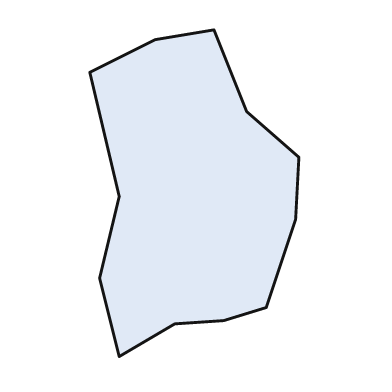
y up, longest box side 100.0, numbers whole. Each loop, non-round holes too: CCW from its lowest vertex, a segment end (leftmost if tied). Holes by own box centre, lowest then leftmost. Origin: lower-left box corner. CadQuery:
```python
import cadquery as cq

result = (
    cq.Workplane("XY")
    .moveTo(9.0, 0.0)
    .lineTo(26.0, 10.0)
    .lineTo(41.0, 11.0)
    .lineTo(54.0, 15.0)
    .lineTo(63.0, 42.0)
    .lineTo(64.0, 61.0)
    .lineTo(48.0, 75.0)
    .lineTo(38.0, 100.0)
    .lineTo(20.0, 97.0)
    .lineTo(0.0, 87.0)
    .lineTo(9.0, 49.0)
    .lineTo(3.0, 24.0)
    .close()
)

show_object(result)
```